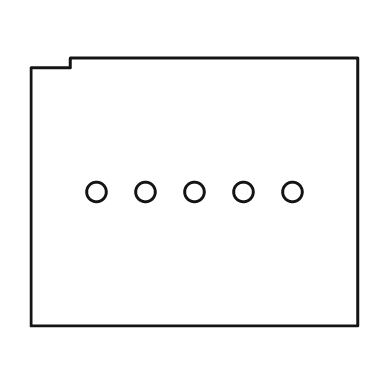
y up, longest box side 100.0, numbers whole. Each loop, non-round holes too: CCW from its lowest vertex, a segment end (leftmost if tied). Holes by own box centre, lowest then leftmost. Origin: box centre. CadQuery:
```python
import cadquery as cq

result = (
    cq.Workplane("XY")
    .moveTo(-50.0, -41.0)
    .lineTo(50.0, -41.0)
    .lineTo(50.0, 41.0)
    .lineTo(-38.0, 41.0)
    .lineTo(-38.0, 38.0)
    .lineTo(-50.0, 38.0)
    .close()
    .moveTo(-30.0, 0.0)
    .circle(3.0)
    .moveTo(-15.0, 0.0)
    .circle(3.0)
    .moveTo(0.0, 0.0)
    .circle(3.0)
    .moveTo(15.0, 0.0)
    .circle(3.0)
    .moveTo(30.0, 0.0)
    .circle(3.0)
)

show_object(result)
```